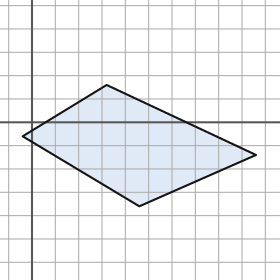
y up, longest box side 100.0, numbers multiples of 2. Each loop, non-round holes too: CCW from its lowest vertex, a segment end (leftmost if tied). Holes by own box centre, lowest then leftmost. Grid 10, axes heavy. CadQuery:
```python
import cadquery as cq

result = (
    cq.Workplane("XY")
    .moveTo(46.0, -36.0)
    .lineTo(96.0, -14.0)
    .lineTo(32.0, 16.0)
    .lineTo(-4.0, -6.0)
    .close()
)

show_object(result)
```